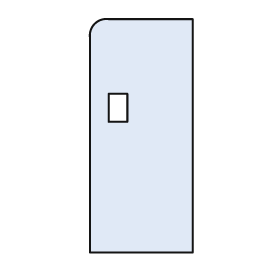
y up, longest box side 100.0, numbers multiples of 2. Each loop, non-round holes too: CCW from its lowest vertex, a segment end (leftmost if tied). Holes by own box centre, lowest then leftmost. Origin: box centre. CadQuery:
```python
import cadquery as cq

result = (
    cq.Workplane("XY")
    .moveTo(-22.0, -50.0)
    .lineTo(22.0, -50.0)
    .lineTo(22.0, 50.0)
    .lineTo(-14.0, 50.0)
    .threePointArc((-20.0, 48.0), (-22.0, 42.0))
    .close()
    .moveTo(-14.0, 6.0)
    .lineTo(-6.0, 6.0)
    .lineTo(-6.0, 18.0)
    .lineTo(-14.0, 18.0)
    .close()
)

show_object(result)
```